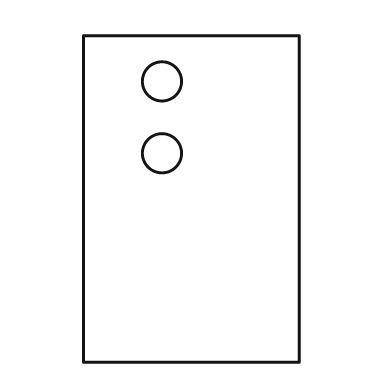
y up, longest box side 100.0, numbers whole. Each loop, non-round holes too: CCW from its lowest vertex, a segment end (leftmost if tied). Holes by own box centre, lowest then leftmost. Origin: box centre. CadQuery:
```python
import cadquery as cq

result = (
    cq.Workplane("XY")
    .moveTo(-33.0, -50.0)
    .lineTo(33.0, -50.0)
    .lineTo(33.0, 50.0)
    .lineTo(-33.0, 50.0)
    .close()
    .moveTo(-9.0, 14.0)
    .circle(6.0)
    .moveTo(-9.0, 36.0)
    .circle(6.0)
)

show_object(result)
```